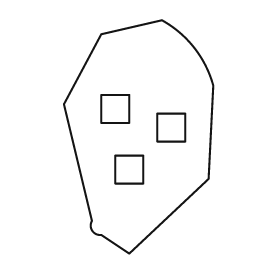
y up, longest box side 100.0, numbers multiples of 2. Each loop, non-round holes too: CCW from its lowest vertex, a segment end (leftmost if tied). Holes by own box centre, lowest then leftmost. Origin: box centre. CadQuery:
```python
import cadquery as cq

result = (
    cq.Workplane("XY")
    .moveTo(-4.0, -50.0)
    .lineTo(30.0, -18.0)
    .lineTo(32.0, 22.0)
    .threePointArc((24.0, 38.0), (10.0, 50.0))
    .lineTo(-16.0, 44.0)
    .lineTo(-32.0, 14.0)
    .lineTo(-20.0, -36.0)
    .threePointArc((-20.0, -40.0), (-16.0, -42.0))
    .close()
    .moveTo(-10.0, -20.0)
    .lineTo(2.0, -20.0)
    .lineTo(2.0, -8.0)
    .lineTo(-10.0, -8.0)
    .close()
    .moveTo(8.0, -2.0)
    .lineTo(20.0, -2.0)
    .lineTo(20.0, 10.0)
    .lineTo(8.0, 10.0)
    .close()
    .moveTo(-16.0, 6.0)
    .lineTo(-4.0, 6.0)
    .lineTo(-4.0, 18.0)
    .lineTo(-16.0, 18.0)
    .close()
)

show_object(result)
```